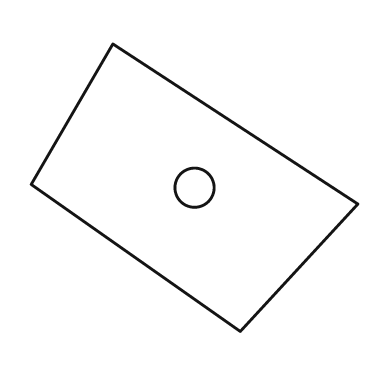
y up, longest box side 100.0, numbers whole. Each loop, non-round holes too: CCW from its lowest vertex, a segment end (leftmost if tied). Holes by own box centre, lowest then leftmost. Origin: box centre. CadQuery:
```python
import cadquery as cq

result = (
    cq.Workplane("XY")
    .moveTo(14.0, -44.0)
    .lineTo(50.0, -5.0)
    .lineTo(-25.0, 44.0)
    .lineTo(-50.0, 1.0)
    .close()
    .moveTo(0.0, 0.0)
    .circle(6.0)
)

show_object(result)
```